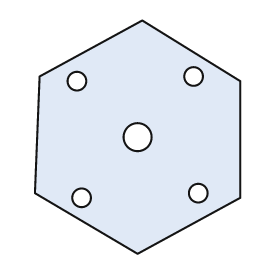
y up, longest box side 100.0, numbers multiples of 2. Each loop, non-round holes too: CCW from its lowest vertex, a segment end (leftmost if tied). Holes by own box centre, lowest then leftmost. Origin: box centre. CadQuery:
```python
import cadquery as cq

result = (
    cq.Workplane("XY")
    .moveTo(0.0, -50.0)
    .lineTo(44.0, -26.0)
    .lineTo(44.0, 24.0)
    .lineTo(2.0, 50.0)
    .lineTo(-42.0, 26.0)
    .lineTo(-44.0, -24.0)
    .close()
    .moveTo(-24.0, -26.0)
    .circle(4.0)
    .moveTo(26.0, -24.0)
    .circle(4.0)
    .moveTo(0.0, 0.0)
    .circle(6.0)
    .moveTo(-26.0, 24.0)
    .circle(4.0)
    .moveTo(24.0, 26.0)
    .circle(4.0)
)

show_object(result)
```